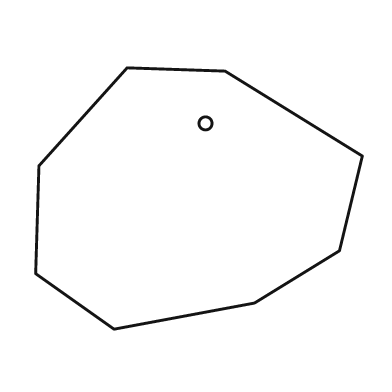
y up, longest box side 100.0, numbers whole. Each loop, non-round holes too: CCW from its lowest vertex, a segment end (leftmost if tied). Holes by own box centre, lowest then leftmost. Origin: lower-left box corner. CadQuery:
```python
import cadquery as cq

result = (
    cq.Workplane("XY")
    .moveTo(24.0, 0.0)
    .lineTo(67.0, 8.0)
    .lineTo(93.0, 24.0)
    .lineTo(100.0, 53.0)
    .lineTo(58.0, 79.0)
    .lineTo(28.0, 80.0)
    .lineTo(1.0, 50.0)
    .lineTo(0.0, 17.0)
    .close()
    .moveTo(52.0, 63.0)
    .circle(2.0)
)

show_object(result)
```